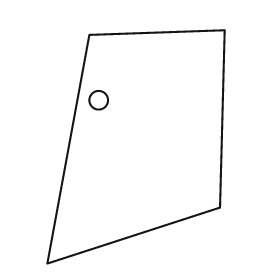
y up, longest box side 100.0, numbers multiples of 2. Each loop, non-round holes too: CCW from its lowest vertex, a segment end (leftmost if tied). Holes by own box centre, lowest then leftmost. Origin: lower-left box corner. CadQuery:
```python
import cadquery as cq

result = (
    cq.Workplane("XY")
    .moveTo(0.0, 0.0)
    .lineTo(74.0, 24.0)
    .lineTo(76.0, 100.0)
    .lineTo(18.0, 98.0)
    .close()
    .moveTo(22.0, 70.0)
    .circle(4.0)
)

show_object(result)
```